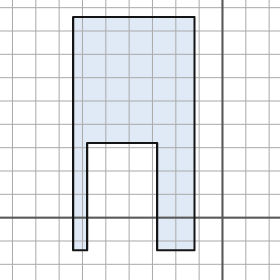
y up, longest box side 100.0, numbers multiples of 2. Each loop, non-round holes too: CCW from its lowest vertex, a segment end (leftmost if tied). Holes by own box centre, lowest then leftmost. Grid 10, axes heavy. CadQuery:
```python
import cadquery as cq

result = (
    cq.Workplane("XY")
    .moveTo(-64.0, -14.0)
    .lineTo(-58.0, -14.0)
    .lineTo(-58.0, 32.0)
    .lineTo(-28.0, 32.0)
    .lineTo(-28.0, -14.0)
    .lineTo(-12.0, -14.0)
    .lineTo(-12.0, 86.0)
    .lineTo(-64.0, 86.0)
    .close()
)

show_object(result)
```